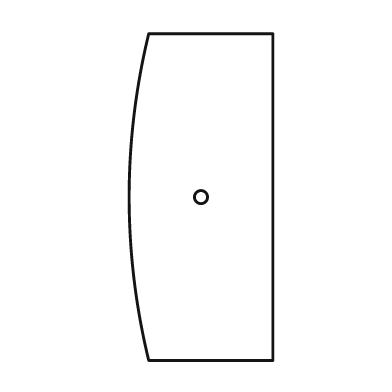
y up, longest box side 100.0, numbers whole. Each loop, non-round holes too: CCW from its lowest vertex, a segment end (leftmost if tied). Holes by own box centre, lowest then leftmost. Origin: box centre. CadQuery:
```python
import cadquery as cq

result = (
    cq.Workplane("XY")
    .moveTo(-16.0, -50.0)
    .lineTo(22.0, -50.0)
    .lineTo(22.0, 50.0)
    .lineTo(-16.0, 50.0)
    .threePointArc((-22.0, 0.0), (-16.0, -50.0))
    .close()
    .moveTo(0.0, 0.0)
    .circle(2.0)
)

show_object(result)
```